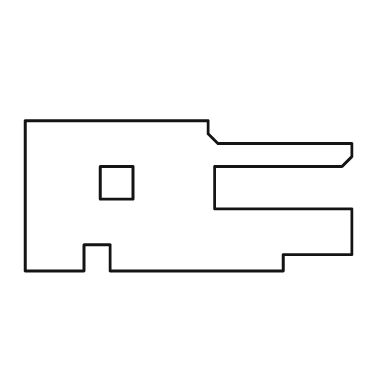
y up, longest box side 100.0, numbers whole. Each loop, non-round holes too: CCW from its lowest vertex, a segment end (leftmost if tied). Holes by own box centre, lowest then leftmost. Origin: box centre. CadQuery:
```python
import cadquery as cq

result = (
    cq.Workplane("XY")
    .moveTo(-50.0, -23.0)
    .lineTo(-32.0, -23.0)
    .lineTo(-32.0, -15.0)
    .lineTo(-24.0, -15.0)
    .lineTo(-24.0, -23.0)
    .lineTo(29.0, -23.0)
    .lineTo(29.0, -18.0)
    .lineTo(50.0, -18.0)
    .lineTo(50.0, -4.0)
    .lineTo(8.0, -4.0)
    .lineTo(8.0, 9.0)
    .lineTo(47.0, 9.0)
    .lineTo(50.0, 12.0)
    .lineTo(50.0, 16.0)
    .lineTo(9.0, 16.0)
    .lineTo(6.0, 19.0)
    .lineTo(6.0, 23.0)
    .lineTo(-50.0, 23.0)
    .close()
    .moveTo(-27.0, -1.0)
    .lineTo(-17.0, -1.0)
    .lineTo(-17.0, 9.0)
    .lineTo(-27.0, 9.0)
    .close()
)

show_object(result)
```